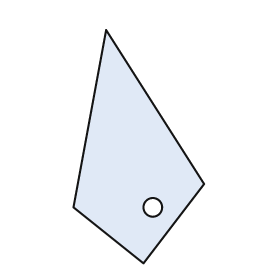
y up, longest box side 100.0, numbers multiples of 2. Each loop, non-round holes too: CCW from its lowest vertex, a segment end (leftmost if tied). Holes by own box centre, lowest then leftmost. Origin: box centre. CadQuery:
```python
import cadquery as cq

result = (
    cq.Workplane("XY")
    .moveTo(2.0, -50.0)
    .lineTo(28.0, -16.0)
    .lineTo(-14.0, 50.0)
    .lineTo(-28.0, -26.0)
    .close()
    .moveTo(6.0, -26.0)
    .circle(4.0)
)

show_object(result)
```